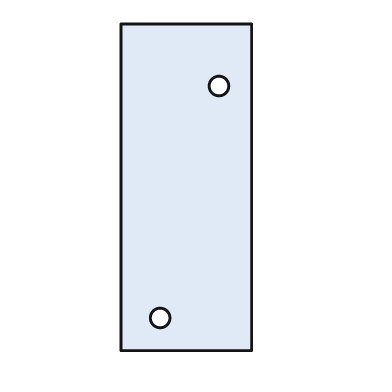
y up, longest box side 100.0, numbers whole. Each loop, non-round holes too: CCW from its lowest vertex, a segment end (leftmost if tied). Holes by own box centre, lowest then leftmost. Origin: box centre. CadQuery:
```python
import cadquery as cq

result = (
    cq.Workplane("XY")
    .moveTo(-20.0, -50.0)
    .lineTo(20.0, -50.0)
    .lineTo(20.0, 50.0)
    .lineTo(-20.0, 50.0)
    .close()
    .moveTo(-8.0, -40.0)
    .circle(3.0)
    .moveTo(10.0, 31.0)
    .circle(3.0)
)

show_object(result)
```